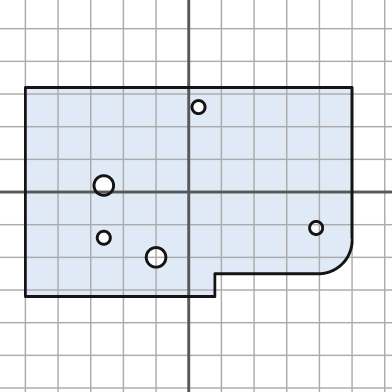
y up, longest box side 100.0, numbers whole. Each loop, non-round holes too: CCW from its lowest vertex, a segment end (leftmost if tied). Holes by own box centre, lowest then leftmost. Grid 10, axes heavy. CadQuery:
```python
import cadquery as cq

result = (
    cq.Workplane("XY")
    .moveTo(-50.0, -32.0)
    .lineTo(8.0, -32.0)
    .lineTo(8.0, -25.0)
    .lineTo(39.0, -25.0)
    .threePointArc((47.0, -22.0), (50.0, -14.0))
    .lineTo(50.0, 32.0)
    .lineTo(-50.0, 32.0)
    .close()
    .moveTo(-10.0, -20.0)
    .circle(3.0)
    .moveTo(-26.0, -14.0)
    .circle(2.0)
    .moveTo(39.0, -11.0)
    .circle(2.0)
    .moveTo(-26.0, 2.0)
    .circle(3.0)
    .moveTo(3.0, 26.0)
    .circle(2.0)
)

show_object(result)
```